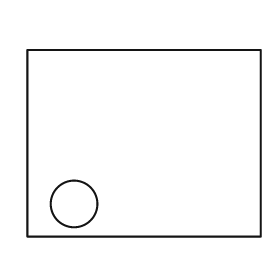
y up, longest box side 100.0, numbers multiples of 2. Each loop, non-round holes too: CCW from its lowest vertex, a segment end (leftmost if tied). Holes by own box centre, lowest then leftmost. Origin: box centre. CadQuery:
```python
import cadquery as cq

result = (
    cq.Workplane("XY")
    .moveTo(-50.0, -40.0)
    .lineTo(50.0, -40.0)
    .lineTo(50.0, 40.0)
    .lineTo(-50.0, 40.0)
    .close()
    .moveTo(-30.0, -26.0)
    .circle(10.0)
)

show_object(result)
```